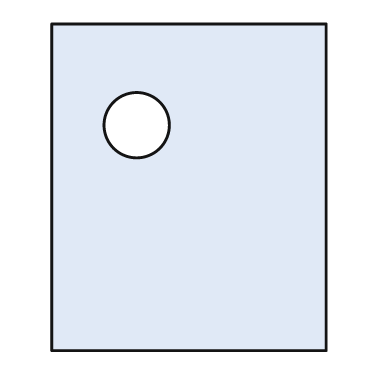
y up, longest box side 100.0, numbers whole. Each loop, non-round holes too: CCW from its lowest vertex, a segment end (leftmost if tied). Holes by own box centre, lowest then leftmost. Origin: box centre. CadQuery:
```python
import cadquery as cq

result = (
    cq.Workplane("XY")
    .moveTo(-42.0, -50.0)
    .lineTo(42.0, -50.0)
    .lineTo(42.0, 50.0)
    .lineTo(-42.0, 50.0)
    .close()
    .moveTo(-16.0, 19.0)
    .circle(10.0)
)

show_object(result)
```